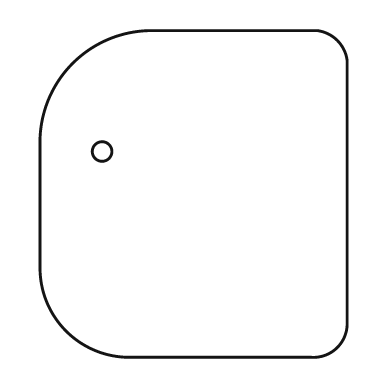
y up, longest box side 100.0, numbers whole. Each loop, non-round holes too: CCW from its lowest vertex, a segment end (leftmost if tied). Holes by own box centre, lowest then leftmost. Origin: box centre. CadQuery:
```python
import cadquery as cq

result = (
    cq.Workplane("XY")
    .moveTo(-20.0, -50.0)
    .lineTo(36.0, -50.0)
    .threePointArc((44.0, -47.0), (47.0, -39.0))
    .lineTo(47.0, 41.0)
    .threePointArc((44.0, 47.0), (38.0, 50.0))
    .lineTo(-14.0, 50.0)
    .threePointArc((-37.0, 40.0), (-47.0, 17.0))
    .lineTo(-47.0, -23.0)
    .threePointArc((-39.0, -42.0), (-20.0, -50.0))
    .close()
    .moveTo(-28.0, 13.0)
    .circle(3.0)
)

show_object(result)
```